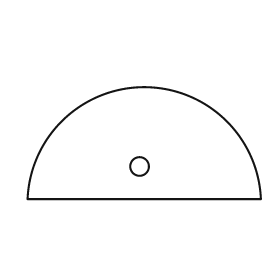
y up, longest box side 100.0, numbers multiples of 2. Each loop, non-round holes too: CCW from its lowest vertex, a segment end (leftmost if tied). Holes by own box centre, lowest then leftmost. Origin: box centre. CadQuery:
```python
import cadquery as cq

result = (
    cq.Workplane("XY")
    .moveTo(-50.0, -24.0)
    .lineTo(50.0, -24.0)
    .threePointArc((0.0, 24.0), (-50.0, -24.0))
    .close()
    .moveTo(-2.0, -10.0)
    .circle(4.0)
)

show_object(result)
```